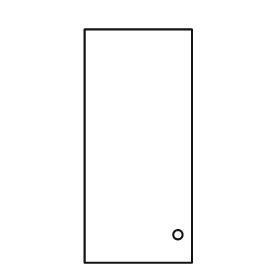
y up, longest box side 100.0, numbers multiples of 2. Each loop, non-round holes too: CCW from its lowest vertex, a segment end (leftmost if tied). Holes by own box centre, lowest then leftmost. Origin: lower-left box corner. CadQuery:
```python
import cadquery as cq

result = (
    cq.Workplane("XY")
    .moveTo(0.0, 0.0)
    .lineTo(46.0, 0.0)
    .lineTo(46.0, 100.0)
    .lineTo(0.0, 100.0)
    .close()
    .moveTo(40.0, 12.0)
    .circle(2.0)
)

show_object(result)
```